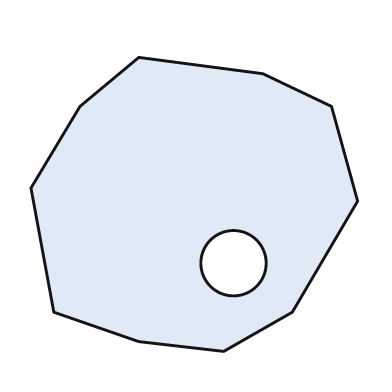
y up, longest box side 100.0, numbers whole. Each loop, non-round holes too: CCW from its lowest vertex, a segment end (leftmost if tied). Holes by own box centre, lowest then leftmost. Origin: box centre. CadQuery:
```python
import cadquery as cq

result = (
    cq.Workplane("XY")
    .moveTo(9.0, -45.0)
    .lineTo(30.0, -33.0)
    .lineTo(50.0, 1.0)
    .lineTo(42.0, 30.0)
    .lineTo(21.0, 40.0)
    .lineTo(-17.0, 45.0)
    .lineTo(-35.0, 30.0)
    .lineTo(-50.0, 5.0)
    .lineTo(-43.0, -33.0)
    .lineTo(-17.0, -42.0)
    .close()
    .moveTo(12.0, -18.0)
    .circle(10.0)
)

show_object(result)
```